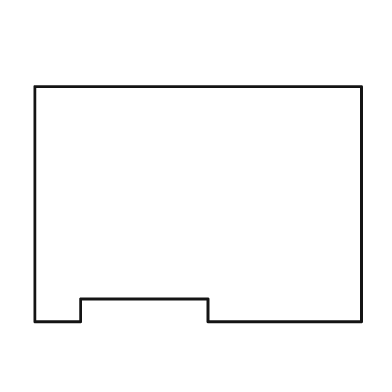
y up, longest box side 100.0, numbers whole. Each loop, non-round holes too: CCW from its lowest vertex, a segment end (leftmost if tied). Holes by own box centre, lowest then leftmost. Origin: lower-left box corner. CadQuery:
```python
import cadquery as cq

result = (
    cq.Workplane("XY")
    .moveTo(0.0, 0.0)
    .lineTo(14.0, 0.0)
    .lineTo(14.0, 7.0)
    .lineTo(53.0, 7.0)
    .lineTo(53.0, 0.0)
    .lineTo(100.0, 0.0)
    .lineTo(100.0, 72.0)
    .lineTo(0.0, 72.0)
    .close()
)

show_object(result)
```